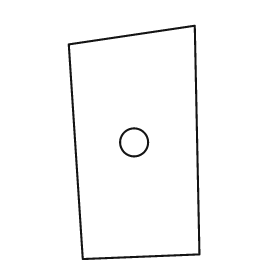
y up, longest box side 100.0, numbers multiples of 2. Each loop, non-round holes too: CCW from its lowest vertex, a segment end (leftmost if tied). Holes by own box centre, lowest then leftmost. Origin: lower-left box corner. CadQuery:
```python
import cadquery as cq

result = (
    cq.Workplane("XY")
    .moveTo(6.0, 0.0)
    .lineTo(56.0, 2.0)
    .lineTo(54.0, 100.0)
    .lineTo(0.0, 92.0)
    .close()
    .moveTo(28.0, 50.0)
    .circle(6.0)
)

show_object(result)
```